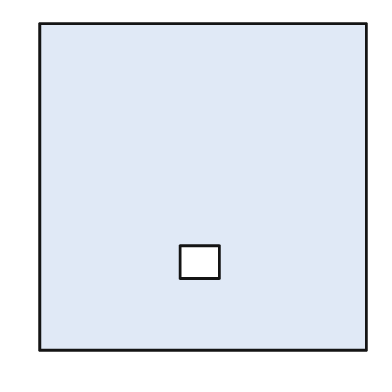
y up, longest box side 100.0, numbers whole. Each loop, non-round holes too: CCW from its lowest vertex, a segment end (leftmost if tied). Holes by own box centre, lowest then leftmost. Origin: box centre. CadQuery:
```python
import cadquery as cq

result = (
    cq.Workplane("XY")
    .moveTo(-50.0, -50.0)
    .lineTo(50.0, -50.0)
    .lineTo(50.0, 50.0)
    .lineTo(-50.0, 50.0)
    .close()
    .moveTo(-7.0, -28.0)
    .lineTo(5.0, -28.0)
    .lineTo(5.0, -18.0)
    .lineTo(-7.0, -18.0)
    .close()
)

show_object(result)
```